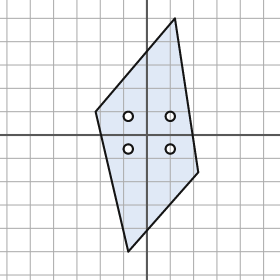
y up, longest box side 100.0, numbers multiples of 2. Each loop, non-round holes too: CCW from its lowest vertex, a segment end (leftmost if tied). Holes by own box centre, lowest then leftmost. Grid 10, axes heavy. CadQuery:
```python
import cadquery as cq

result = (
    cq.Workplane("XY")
    .moveTo(-8.0, -50.0)
    .lineTo(22.0, -16.0)
    .lineTo(12.0, 50.0)
    .lineTo(-22.0, 10.0)
    .close()
    .moveTo(-8.0, -6.0)
    .circle(2.0)
    .moveTo(10.0, -6.0)
    .circle(2.0)
    .moveTo(-8.0, 8.0)
    .circle(2.0)
    .moveTo(10.0, 8.0)
    .circle(2.0)
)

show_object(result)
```